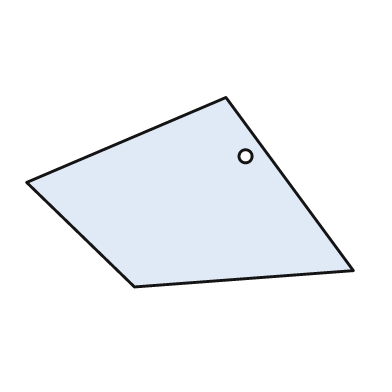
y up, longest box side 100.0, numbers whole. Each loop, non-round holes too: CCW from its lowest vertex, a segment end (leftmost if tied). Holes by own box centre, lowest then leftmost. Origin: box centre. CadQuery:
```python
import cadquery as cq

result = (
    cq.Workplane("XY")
    .moveTo(-17.0, -29.0)
    .lineTo(50.0, -24.0)
    .lineTo(11.0, 29.0)
    .lineTo(-50.0, 3.0)
    .close()
    .moveTo(17.0, 11.0)
    .circle(2.0)
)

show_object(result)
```